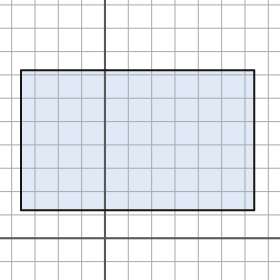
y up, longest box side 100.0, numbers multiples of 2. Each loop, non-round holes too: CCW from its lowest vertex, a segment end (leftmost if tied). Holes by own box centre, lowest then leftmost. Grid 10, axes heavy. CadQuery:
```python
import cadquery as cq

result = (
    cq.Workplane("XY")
    .moveTo(-36.0, 12.0)
    .lineTo(64.0, 12.0)
    .lineTo(64.0, 72.0)
    .lineTo(-36.0, 72.0)
    .close()
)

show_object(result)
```